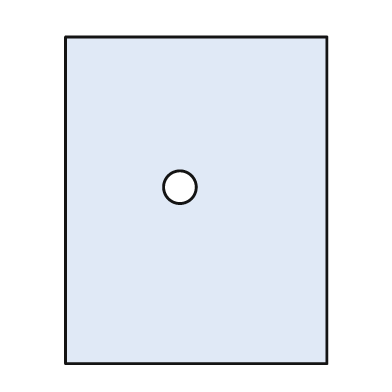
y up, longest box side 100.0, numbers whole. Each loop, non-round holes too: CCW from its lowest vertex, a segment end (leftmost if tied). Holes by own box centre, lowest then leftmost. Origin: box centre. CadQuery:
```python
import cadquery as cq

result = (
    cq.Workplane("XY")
    .moveTo(-40.0, -50.0)
    .lineTo(40.0, -50.0)
    .lineTo(40.0, 50.0)
    .lineTo(-40.0, 50.0)
    .close()
    .moveTo(-5.0, 4.0)
    .circle(5.0)
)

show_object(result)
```